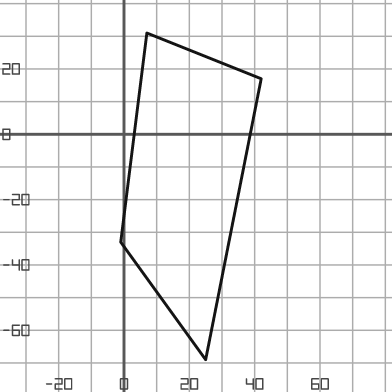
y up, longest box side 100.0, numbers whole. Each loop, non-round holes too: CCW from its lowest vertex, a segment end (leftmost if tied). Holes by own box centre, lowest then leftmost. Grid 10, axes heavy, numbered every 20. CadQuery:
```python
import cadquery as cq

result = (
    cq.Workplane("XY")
    .moveTo(25.0, -69.0)
    .lineTo(42.0, 17.0)
    .lineTo(7.0, 31.0)
    .lineTo(-1.0, -33.0)
    .close()
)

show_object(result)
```